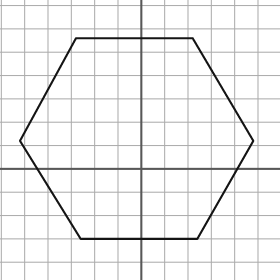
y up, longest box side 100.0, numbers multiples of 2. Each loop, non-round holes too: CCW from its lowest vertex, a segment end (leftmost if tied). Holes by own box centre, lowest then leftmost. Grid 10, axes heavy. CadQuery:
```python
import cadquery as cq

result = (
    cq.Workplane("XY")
    .moveTo(-26.0, -30.0)
    .lineTo(24.0, -30.0)
    .lineTo(48.0, 12.0)
    .lineTo(22.0, 56.0)
    .lineTo(-28.0, 56.0)
    .lineTo(-52.0, 12.0)
    .close()
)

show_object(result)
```